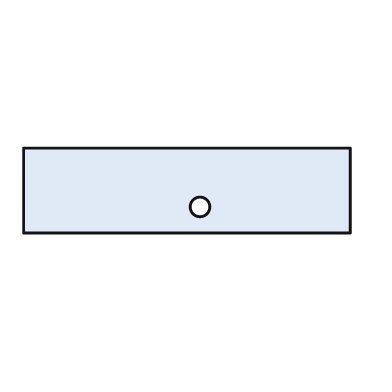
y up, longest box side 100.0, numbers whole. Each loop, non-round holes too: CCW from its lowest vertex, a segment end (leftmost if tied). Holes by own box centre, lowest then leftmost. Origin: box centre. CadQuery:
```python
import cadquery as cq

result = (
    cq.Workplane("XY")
    .moveTo(-50.0, -13.0)
    .lineTo(50.0, -13.0)
    .lineTo(50.0, 13.0)
    .lineTo(-50.0, 13.0)
    .close()
    .moveTo(4.0, -5.0)
    .circle(3.0)
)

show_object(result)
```